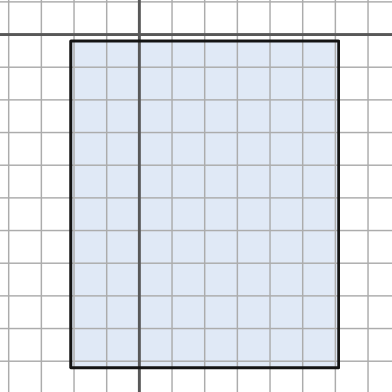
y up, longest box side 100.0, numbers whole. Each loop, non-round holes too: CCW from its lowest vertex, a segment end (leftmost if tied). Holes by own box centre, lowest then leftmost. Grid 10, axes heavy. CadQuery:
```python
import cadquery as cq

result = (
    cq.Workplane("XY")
    .moveTo(-21.0, -102.0)
    .lineTo(61.0, -102.0)
    .lineTo(61.0, -2.0)
    .lineTo(-21.0, -2.0)
    .close()
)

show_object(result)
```